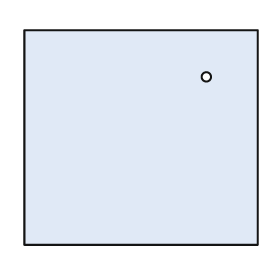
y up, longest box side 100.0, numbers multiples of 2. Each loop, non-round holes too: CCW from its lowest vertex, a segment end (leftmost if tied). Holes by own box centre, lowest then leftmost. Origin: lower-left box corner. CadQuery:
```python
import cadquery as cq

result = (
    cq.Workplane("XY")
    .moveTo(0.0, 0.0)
    .lineTo(100.0, 0.0)
    .lineTo(100.0, 92.0)
    .lineTo(0.0, 92.0)
    .close()
    .moveTo(78.0, 72.0)
    .circle(2.0)
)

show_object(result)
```